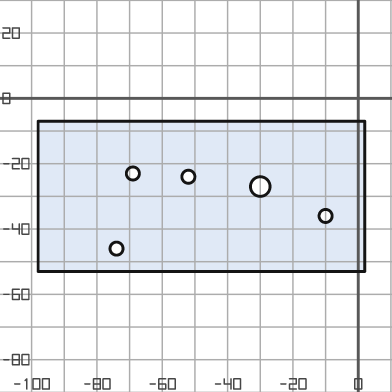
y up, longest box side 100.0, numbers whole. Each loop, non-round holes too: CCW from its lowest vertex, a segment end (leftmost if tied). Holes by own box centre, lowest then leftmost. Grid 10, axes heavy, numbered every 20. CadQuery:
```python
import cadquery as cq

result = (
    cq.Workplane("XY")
    .moveTo(-98.0, -53.0)
    .lineTo(2.0, -53.0)
    .lineTo(2.0, -7.0)
    .lineTo(-98.0, -7.0)
    .close()
    .moveTo(-74.0, -46.0)
    .circle(2.0)
    .moveTo(-10.0, -36.0)
    .circle(2.0)
    .moveTo(-30.0, -27.0)
    .circle(3.0)
    .moveTo(-52.0, -24.0)
    .circle(2.0)
    .moveTo(-69.0, -23.0)
    .circle(2.0)
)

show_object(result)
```